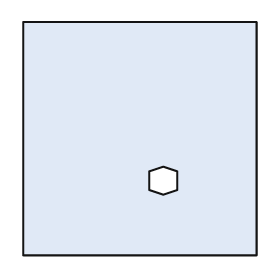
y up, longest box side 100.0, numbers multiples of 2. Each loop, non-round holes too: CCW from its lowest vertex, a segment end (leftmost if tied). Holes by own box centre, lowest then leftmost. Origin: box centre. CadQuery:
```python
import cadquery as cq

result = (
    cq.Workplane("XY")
    .moveTo(-50.0, -50.0)
    .lineTo(50.0, -50.0)
    .lineTo(50.0, 50.0)
    .lineTo(-50.0, 50.0)
    .close()
    .moveTo(10.0, -24.0)
    .lineTo(16.0, -22.0)
    .lineTo(16.0, -14.0)
    .lineTo(10.0, -12.0)
    .lineTo(4.0, -14.0)
    .lineTo(4.0, -22.0)
    .close()
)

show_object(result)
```